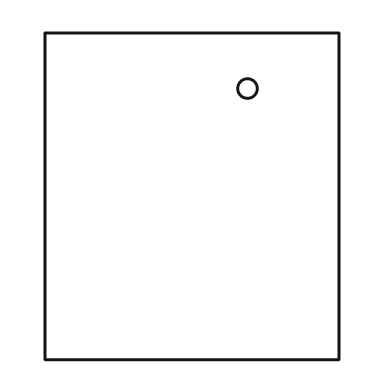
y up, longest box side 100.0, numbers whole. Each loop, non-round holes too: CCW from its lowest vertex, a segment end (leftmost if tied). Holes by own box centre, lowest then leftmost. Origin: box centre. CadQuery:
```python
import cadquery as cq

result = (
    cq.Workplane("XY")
    .moveTo(-45.0, -50.0)
    .lineTo(45.0, -50.0)
    .lineTo(45.0, 50.0)
    .lineTo(-45.0, 50.0)
    .close()
    .moveTo(17.0, 33.0)
    .circle(3.0)
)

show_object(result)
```